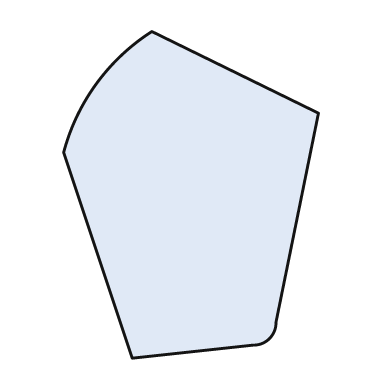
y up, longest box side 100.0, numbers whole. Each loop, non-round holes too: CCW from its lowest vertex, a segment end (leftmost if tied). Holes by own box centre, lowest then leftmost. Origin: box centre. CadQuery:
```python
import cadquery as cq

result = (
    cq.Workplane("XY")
    .moveTo(-18.0, -50.0)
    .lineTo(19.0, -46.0)
    .threePointArc((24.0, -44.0), (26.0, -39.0))
    .lineTo(39.0, 25.0)
    .lineTo(-12.0, 50.0)
    .threePointArc((-29.0, 34.0), (-39.0, 13.0))
    .close()
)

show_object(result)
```